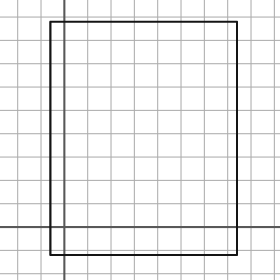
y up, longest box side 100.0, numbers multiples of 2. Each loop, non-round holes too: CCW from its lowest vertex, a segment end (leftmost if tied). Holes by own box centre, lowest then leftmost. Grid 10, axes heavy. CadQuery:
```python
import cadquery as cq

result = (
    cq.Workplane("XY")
    .moveTo(-6.0, -12.0)
    .lineTo(74.0, -12.0)
    .lineTo(74.0, 88.0)
    .lineTo(-6.0, 88.0)
    .close()
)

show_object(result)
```